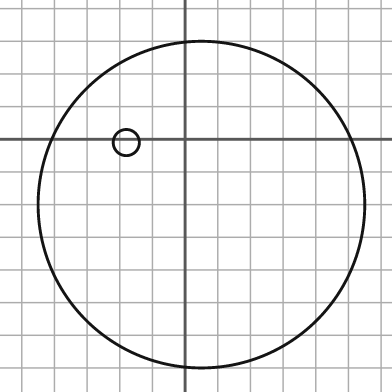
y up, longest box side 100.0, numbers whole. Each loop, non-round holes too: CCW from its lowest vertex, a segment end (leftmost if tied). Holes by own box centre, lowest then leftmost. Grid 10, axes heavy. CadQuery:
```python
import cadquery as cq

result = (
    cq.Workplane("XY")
    .moveTo(5.0, -20.0)
    .circle(50.0)
    .moveTo(-18.0, -1.0)
    .circle(4.0)
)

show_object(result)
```